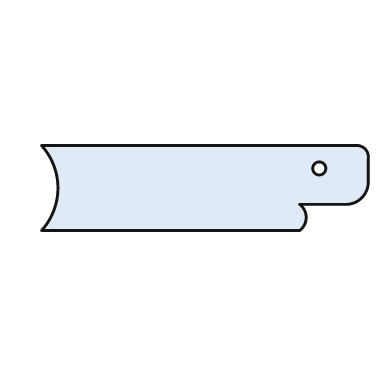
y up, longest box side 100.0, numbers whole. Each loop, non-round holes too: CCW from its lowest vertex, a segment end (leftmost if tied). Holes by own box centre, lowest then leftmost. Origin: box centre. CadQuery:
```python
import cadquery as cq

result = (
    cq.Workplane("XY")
    .moveTo(-50.0, -13.0)
    .lineTo(29.0, -13.0)
    .threePointArc((31.0, -9.0), (29.0, -5.0))
    .lineTo(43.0, -5.0)
    .threePointArc((48.0, -3.0), (50.0, 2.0))
    .lineTo(50.0, 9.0)
    .threePointArc((49.0, 12.0), (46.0, 13.0))
    .lineTo(-50.0, 13.0)
    .threePointArc((-45.0, 0.0), (-50.0, -13.0))
    .close()
    .moveTo(35.0, 6.0)
    .circle(2.0)
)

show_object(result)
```